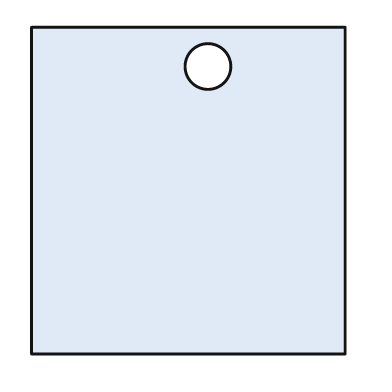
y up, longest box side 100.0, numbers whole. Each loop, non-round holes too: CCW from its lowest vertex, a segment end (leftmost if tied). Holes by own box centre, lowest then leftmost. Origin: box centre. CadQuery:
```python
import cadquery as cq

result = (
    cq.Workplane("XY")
    .moveTo(-48.0, -50.0)
    .lineTo(48.0, -50.0)
    .lineTo(48.0, 50.0)
    .lineTo(-48.0, 50.0)
    .close()
    .moveTo(6.0, 38.0)
    .circle(7.0)
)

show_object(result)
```